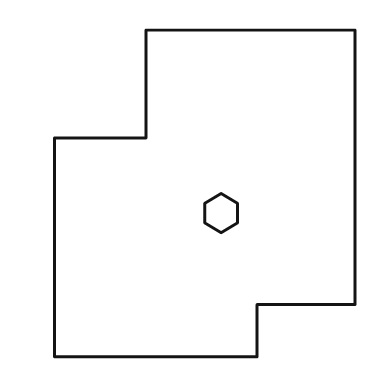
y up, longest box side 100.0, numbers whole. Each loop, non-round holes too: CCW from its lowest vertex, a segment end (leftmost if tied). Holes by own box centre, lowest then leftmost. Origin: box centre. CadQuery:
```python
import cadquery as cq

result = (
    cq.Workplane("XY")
    .moveTo(-46.0, -50.0)
    .lineTo(16.0, -50.0)
    .lineTo(16.0, -34.0)
    .lineTo(46.0, -34.0)
    .lineTo(46.0, 50.0)
    .lineTo(-18.0, 50.0)
    .lineTo(-18.0, 17.0)
    .lineTo(-46.0, 17.0)
    .close()
    .moveTo(5.0, -12.0)
    .lineTo(10.0, -9.0)
    .lineTo(10.0, -3.0)
    .lineTo(5.0, 0.0)
    .lineTo(0.0, -3.0)
    .lineTo(0.0, -9.0)
    .close()
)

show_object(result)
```